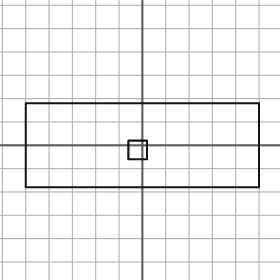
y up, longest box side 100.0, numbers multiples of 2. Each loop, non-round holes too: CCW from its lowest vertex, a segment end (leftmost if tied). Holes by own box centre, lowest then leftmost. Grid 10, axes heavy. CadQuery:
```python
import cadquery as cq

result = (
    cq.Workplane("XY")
    .moveTo(-50.0, -18.0)
    .lineTo(50.0, -18.0)
    .lineTo(50.0, 18.0)
    .lineTo(-50.0, 18.0)
    .close()
    .moveTo(-6.0, -6.0)
    .lineTo(2.0, -6.0)
    .lineTo(2.0, 2.0)
    .lineTo(-6.0, 2.0)
    .close()
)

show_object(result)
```